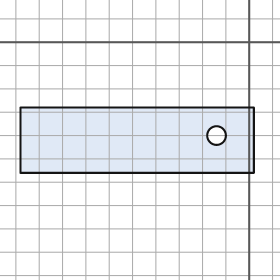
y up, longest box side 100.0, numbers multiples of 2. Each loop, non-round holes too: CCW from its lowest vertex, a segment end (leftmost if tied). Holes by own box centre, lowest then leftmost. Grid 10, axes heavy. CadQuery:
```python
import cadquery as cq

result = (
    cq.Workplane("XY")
    .moveTo(-98.0, -56.0)
    .lineTo(2.0, -56.0)
    .lineTo(2.0, -28.0)
    .lineTo(-98.0, -28.0)
    .close()
    .moveTo(-14.0, -40.0)
    .circle(4.0)
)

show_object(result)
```